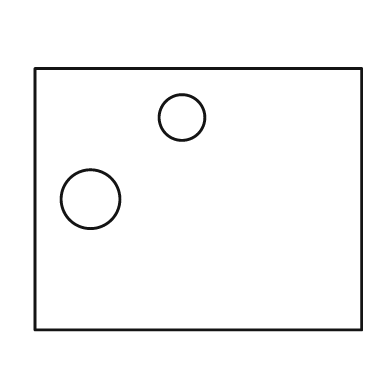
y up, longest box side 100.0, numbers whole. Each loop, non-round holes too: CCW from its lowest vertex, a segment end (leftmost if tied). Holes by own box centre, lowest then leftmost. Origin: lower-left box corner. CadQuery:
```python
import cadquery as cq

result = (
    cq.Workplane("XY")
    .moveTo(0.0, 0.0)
    .lineTo(100.0, 0.0)
    .lineTo(100.0, 80.0)
    .lineTo(0.0, 80.0)
    .close()
    .moveTo(17.0, 40.0)
    .circle(9.0)
    .moveTo(45.0, 65.0)
    .circle(7.0)
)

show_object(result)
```